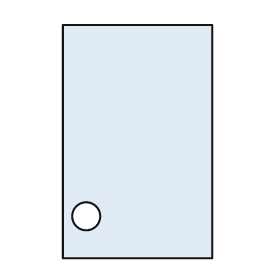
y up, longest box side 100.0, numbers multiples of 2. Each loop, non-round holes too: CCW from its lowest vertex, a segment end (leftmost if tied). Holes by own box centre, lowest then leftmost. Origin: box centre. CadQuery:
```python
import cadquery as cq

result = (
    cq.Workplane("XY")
    .moveTo(-32.0, -50.0)
    .lineTo(32.0, -50.0)
    .lineTo(32.0, 50.0)
    .lineTo(-32.0, 50.0)
    .close()
    .moveTo(-22.0, -32.0)
    .circle(6.0)
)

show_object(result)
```